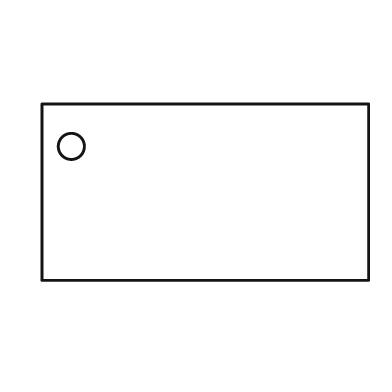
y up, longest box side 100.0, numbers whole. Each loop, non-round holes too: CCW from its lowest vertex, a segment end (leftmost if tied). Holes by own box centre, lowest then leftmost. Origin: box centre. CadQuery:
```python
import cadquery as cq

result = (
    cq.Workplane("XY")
    .moveTo(-50.0, -27.0)
    .lineTo(50.0, -27.0)
    .lineTo(50.0, 27.0)
    .lineTo(-50.0, 27.0)
    .close()
    .moveTo(-41.0, 14.0)
    .circle(4.0)
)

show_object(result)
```